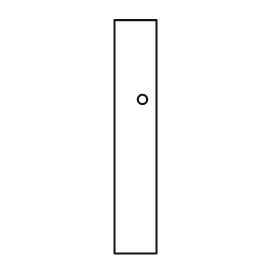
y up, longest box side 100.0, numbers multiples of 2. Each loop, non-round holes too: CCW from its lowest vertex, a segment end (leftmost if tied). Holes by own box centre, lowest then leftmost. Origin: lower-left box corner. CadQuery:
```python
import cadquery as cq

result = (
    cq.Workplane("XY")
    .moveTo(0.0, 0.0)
    .lineTo(18.0, 0.0)
    .lineTo(18.0, 100.0)
    .lineTo(0.0, 100.0)
    .close()
    .moveTo(12.0, 66.0)
    .circle(2.0)
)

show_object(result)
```